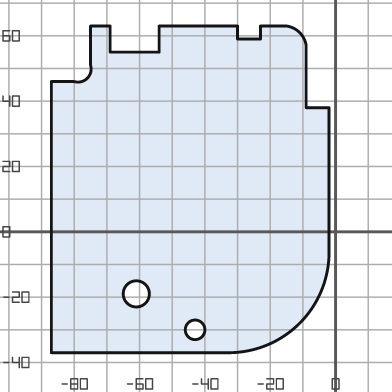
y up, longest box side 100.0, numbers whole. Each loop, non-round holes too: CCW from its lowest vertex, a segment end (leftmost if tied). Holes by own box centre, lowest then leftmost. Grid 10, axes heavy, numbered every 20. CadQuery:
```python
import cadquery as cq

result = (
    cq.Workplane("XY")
    .moveTo(-87.0, -37.0)
    .lineTo(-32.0, -37.0)
    .threePointArc((-11.0, -28.0), (-2.0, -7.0))
    .lineTo(-2.0, 38.0)
    .lineTo(-9.0, 38.0)
    .lineTo(-9.0, 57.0)
    .threePointArc((-11.0, 61.0), (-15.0, 63.0))
    .lineTo(-23.0, 63.0)
    .lineTo(-23.0, 59.0)
    .lineTo(-30.0, 59.0)
    .lineTo(-30.0, 63.0)
    .lineTo(-54.0, 63.0)
    .lineTo(-54.0, 55.0)
    .lineTo(-69.0, 55.0)
    .lineTo(-69.0, 63.0)
    .lineTo(-75.0, 63.0)
    .lineTo(-75.0, 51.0)
    .threePointArc((-76.0, 47.0), (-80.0, 46.0))
    .lineTo(-87.0, 46.0)
    .close()
    .moveTo(-43.0, -30.0)
    .circle(3.0)
    .moveTo(-61.0, -19.0)
    .circle(4.0)
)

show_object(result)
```